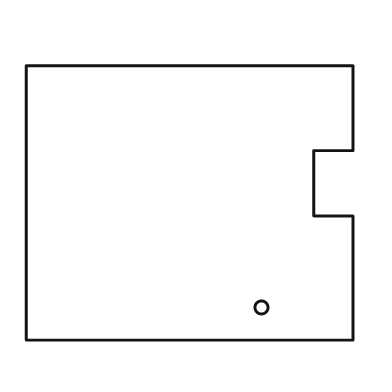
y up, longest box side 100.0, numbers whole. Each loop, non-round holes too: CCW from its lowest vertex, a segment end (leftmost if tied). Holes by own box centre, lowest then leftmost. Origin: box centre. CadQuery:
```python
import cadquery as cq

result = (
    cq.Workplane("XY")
    .moveTo(-50.0, -42.0)
    .lineTo(50.0, -42.0)
    .lineTo(50.0, -4.0)
    .lineTo(38.0, -4.0)
    .lineTo(38.0, 16.0)
    .lineTo(50.0, 16.0)
    .lineTo(50.0, 42.0)
    .lineTo(-50.0, 42.0)
    .close()
    .moveTo(22.0, -32.0)
    .circle(2.0)
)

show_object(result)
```